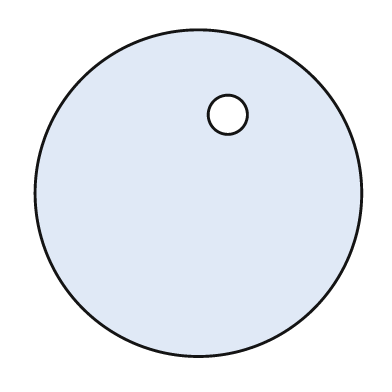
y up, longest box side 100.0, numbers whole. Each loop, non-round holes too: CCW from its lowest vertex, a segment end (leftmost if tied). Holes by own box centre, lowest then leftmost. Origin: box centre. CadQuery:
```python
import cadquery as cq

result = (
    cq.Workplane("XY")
    .moveTo(0.0, 0.0)
    .circle(50.0)
    .moveTo(9.0, 24.0)
    .circle(6.0)
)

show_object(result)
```